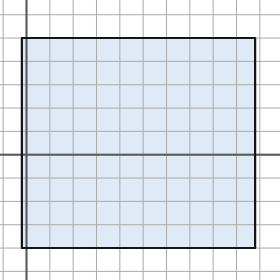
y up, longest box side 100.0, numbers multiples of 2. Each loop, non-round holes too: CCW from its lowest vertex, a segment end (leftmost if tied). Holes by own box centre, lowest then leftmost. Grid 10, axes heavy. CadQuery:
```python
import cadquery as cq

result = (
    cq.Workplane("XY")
    .moveTo(-2.0, -40.0)
    .lineTo(98.0, -40.0)
    .lineTo(98.0, 50.0)
    .lineTo(-2.0, 50.0)
    .close()
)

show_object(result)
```